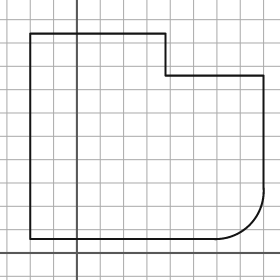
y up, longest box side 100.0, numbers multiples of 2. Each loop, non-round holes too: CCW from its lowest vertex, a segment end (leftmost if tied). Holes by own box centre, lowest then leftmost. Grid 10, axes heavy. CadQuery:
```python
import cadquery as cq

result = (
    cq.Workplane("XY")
    .moveTo(-20.0, 6.0)
    .lineTo(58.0, 6.0)
    .threePointArc((74.0, 12.0), (80.0, 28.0))
    .lineTo(80.0, 76.0)
    .lineTo(38.0, 76.0)
    .lineTo(38.0, 94.0)
    .lineTo(-20.0, 94.0)
    .close()
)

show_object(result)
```